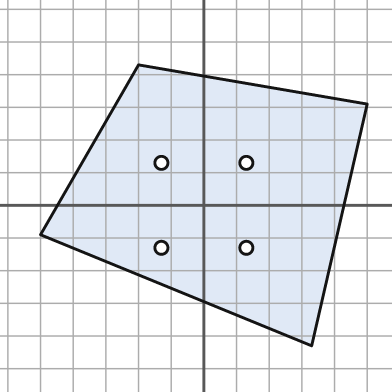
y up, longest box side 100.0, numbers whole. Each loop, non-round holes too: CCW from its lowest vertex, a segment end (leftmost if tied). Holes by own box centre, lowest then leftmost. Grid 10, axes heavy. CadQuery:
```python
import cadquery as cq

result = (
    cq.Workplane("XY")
    .moveTo(33.0, -43.0)
    .lineTo(50.0, 31.0)
    .lineTo(-20.0, 43.0)
    .lineTo(-50.0, -9.0)
    .close()
    .moveTo(-13.0, -13.0)
    .circle(2.0)
    .moveTo(13.0, -13.0)
    .circle(2.0)
    .moveTo(-13.0, 13.0)
    .circle(2.0)
    .moveTo(13.0, 13.0)
    .circle(2.0)
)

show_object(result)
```